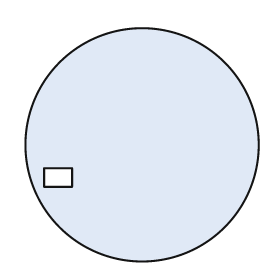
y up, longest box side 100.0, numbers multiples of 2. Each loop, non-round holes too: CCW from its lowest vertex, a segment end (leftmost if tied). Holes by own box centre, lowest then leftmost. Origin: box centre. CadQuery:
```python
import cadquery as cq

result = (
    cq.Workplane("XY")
    .moveTo(0.0, 0.0)
    .circle(50.0)
    .moveTo(-42.0, -18.0)
    .lineTo(-30.0, -18.0)
    .lineTo(-30.0, -10.0)
    .lineTo(-42.0, -10.0)
    .close()
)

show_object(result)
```